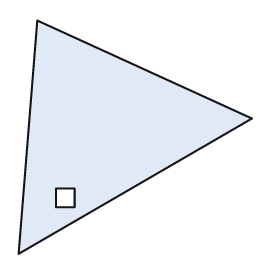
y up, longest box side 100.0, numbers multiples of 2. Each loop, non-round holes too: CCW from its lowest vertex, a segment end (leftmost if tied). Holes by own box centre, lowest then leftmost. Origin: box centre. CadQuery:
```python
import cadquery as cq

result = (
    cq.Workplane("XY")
    .moveTo(-50.0, -50.0)
    .lineTo(50.0, 8.0)
    .lineTo(-42.0, 50.0)
    .close()
    .moveTo(-34.0, -30.0)
    .lineTo(-26.0, -30.0)
    .lineTo(-26.0, -22.0)
    .lineTo(-34.0, -22.0)
    .close()
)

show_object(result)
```